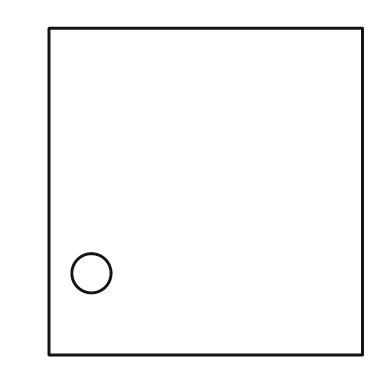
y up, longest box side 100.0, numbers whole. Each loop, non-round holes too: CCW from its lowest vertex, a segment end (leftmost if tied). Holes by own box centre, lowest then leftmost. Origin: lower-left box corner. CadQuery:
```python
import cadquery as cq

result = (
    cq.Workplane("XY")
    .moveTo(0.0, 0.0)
    .lineTo(96.0, 0.0)
    .lineTo(96.0, 100.0)
    .lineTo(0.0, 100.0)
    .close()
    .moveTo(13.0, 25.0)
    .circle(6.0)
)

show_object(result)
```